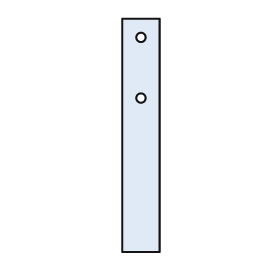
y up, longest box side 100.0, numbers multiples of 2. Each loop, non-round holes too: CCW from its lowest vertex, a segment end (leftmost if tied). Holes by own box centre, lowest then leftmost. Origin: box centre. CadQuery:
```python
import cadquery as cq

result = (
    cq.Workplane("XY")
    .moveTo(-8.0, -50.0)
    .lineTo(8.0, -50.0)
    .lineTo(8.0, 50.0)
    .lineTo(-8.0, 50.0)
    .close()
    .moveTo(0.0, 16.0)
    .circle(2.0)
    .moveTo(0.0, 42.0)
    .circle(2.0)
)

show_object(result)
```